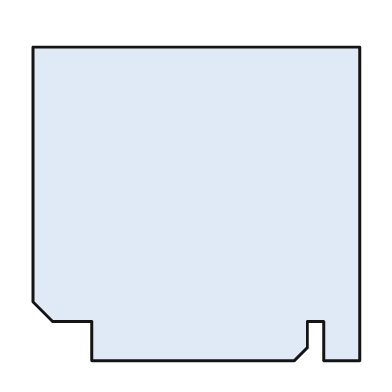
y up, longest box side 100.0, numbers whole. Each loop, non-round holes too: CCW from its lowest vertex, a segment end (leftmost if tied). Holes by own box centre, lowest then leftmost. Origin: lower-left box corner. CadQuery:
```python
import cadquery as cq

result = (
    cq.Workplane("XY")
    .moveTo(18.0, 0.0)
    .lineTo(80.0, 0.0)
    .lineTo(84.0, 4.0)
    .lineTo(84.0, 12.0)
    .lineTo(89.0, 12.0)
    .lineTo(89.0, 0.0)
    .lineTo(100.0, 0.0)
    .lineTo(100.0, 96.0)
    .lineTo(0.0, 96.0)
    .lineTo(0.0, 18.0)
    .lineTo(6.0, 12.0)
    .lineTo(18.0, 12.0)
    .close()
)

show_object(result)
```